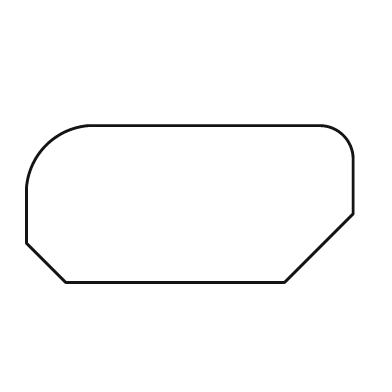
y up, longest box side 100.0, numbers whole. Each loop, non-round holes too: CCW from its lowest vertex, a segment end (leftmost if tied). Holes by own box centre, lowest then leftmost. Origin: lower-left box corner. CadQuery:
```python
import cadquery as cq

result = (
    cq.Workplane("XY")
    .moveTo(12.0, 0.0)
    .lineTo(79.0, 0.0)
    .lineTo(100.0, 21.0)
    .lineTo(100.0, 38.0)
    .threePointArc((97.0, 45.0), (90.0, 48.0))
    .lineTo(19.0, 48.0)
    .threePointArc((6.0, 42.0), (0.0, 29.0))
    .lineTo(0.0, 12.0)
    .close()
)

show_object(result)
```